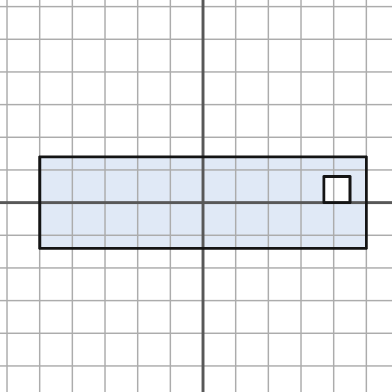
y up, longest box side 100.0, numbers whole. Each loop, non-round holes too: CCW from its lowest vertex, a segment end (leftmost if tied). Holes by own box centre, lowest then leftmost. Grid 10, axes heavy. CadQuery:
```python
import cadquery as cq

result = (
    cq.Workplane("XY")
    .moveTo(-50.0, -14.0)
    .lineTo(50.0, -14.0)
    .lineTo(50.0, 14.0)
    .lineTo(-50.0, 14.0)
    .close()
    .moveTo(37.0, 0.0)
    .lineTo(45.0, 0.0)
    .lineTo(45.0, 8.0)
    .lineTo(37.0, 8.0)
    .close()
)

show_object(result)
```